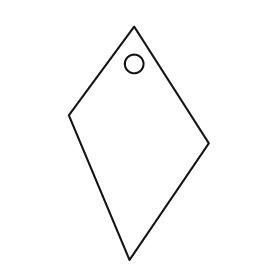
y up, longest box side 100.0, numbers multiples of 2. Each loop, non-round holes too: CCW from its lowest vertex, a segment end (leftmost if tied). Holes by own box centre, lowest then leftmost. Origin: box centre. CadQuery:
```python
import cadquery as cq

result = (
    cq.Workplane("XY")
    .moveTo(-4.0, -50.0)
    .lineTo(30.0, 0.0)
    .lineTo(-2.0, 50.0)
    .lineTo(-30.0, 12.0)
    .close()
    .moveTo(-2.0, 34.0)
    .circle(4.0)
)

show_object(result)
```